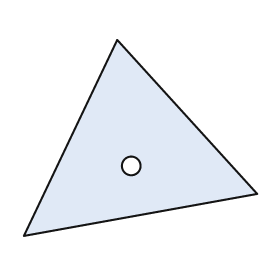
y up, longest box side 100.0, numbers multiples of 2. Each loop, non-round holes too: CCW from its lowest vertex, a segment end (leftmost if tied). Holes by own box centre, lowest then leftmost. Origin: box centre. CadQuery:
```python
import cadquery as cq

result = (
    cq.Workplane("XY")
    .moveTo(-50.0, -42.0)
    .lineTo(50.0, -24.0)
    .lineTo(-10.0, 42.0)
    .close()
    .moveTo(-4.0, -12.0)
    .circle(4.0)
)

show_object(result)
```